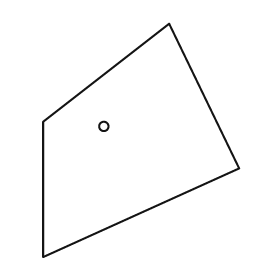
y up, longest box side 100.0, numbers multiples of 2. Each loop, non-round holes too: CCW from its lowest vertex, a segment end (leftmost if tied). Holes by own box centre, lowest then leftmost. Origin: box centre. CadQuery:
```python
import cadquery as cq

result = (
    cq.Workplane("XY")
    .moveTo(-42.0, -50.0)
    .lineTo(42.0, -12.0)
    .lineTo(12.0, 50.0)
    .lineTo(-42.0, 8.0)
    .close()
    .moveTo(-16.0, 6.0)
    .circle(2.0)
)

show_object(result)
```